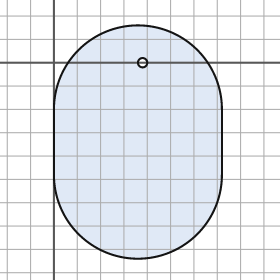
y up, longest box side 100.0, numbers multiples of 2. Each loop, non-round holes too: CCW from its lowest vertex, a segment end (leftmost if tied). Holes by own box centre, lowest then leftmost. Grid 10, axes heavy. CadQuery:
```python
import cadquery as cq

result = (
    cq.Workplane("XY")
    .moveTo(0.0, -48.0)
    .threePointArc((36.0, -84.0), (72.0, -48.0))
    .lineTo(72.0, -20.0)
    .threePointArc((36.0, 16.0), (0.0, -20.0))
    .close()
    .moveTo(38.0, 0.0)
    .circle(2.0)
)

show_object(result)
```